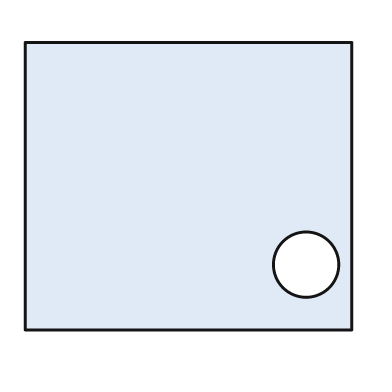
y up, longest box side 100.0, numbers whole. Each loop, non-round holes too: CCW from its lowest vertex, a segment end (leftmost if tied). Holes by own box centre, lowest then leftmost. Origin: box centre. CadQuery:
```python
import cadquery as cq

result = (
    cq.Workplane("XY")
    .moveTo(-50.0, -44.0)
    .lineTo(50.0, -44.0)
    .lineTo(50.0, 44.0)
    .lineTo(-50.0, 44.0)
    .close()
    .moveTo(36.0, -24.0)
    .circle(10.0)
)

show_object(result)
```